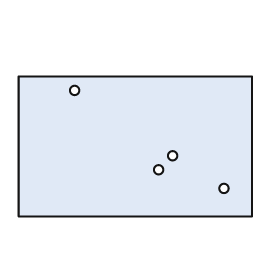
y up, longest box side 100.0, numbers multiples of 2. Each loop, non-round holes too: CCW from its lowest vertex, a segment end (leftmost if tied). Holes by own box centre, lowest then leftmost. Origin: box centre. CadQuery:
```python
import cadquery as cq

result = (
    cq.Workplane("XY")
    .moveTo(-50.0, -30.0)
    .lineTo(50.0, -30.0)
    .lineTo(50.0, 30.0)
    .lineTo(-50.0, 30.0)
    .close()
    .moveTo(38.0, -18.0)
    .circle(2.0)
    .moveTo(10.0, -10.0)
    .circle(2.0)
    .moveTo(16.0, -4.0)
    .circle(2.0)
    .moveTo(-26.0, 24.0)
    .circle(2.0)
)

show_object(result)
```